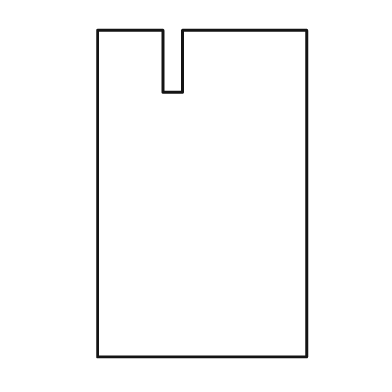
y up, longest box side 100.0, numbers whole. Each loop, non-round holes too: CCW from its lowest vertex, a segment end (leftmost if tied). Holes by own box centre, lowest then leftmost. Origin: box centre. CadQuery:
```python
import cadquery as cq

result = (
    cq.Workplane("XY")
    .moveTo(-32.0, -50.0)
    .lineTo(32.0, -50.0)
    .lineTo(32.0, 50.0)
    .lineTo(-6.0, 50.0)
    .lineTo(-6.0, 31.0)
    .lineTo(-12.0, 31.0)
    .lineTo(-12.0, 50.0)
    .lineTo(-32.0, 50.0)
    .close()
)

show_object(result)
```